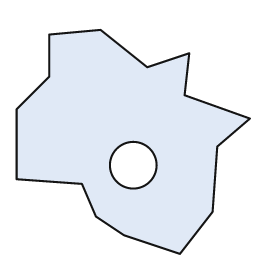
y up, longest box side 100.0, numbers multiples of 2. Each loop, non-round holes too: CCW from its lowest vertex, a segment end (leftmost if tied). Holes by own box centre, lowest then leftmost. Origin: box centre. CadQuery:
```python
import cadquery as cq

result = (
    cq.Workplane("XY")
    .moveTo(20.0, -48.0)
    .lineTo(34.0, -30.0)
    .lineTo(36.0, -2.0)
    .lineTo(50.0, 10.0)
    .lineTo(22.0, 20.0)
    .lineTo(24.0, 38.0)
    .lineTo(6.0, 32.0)
    .lineTo(-14.0, 48.0)
    .lineTo(-36.0, 46.0)
    .lineTo(-36.0, 28.0)
    .lineTo(-50.0, 14.0)
    .lineTo(-50.0, -16.0)
    .lineTo(-22.0, -18.0)
    .lineTo(-16.0, -32.0)
    .lineTo(-4.0, -40.0)
    .close()
    .moveTo(0.0, -10.0)
    .circle(10.0)
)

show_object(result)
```